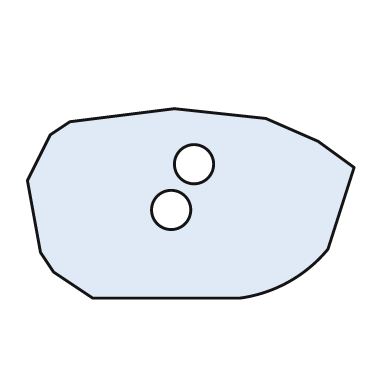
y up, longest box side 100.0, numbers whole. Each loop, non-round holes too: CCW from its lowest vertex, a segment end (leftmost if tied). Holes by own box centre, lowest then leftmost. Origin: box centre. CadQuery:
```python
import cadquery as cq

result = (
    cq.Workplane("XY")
    .moveTo(-30.0, -29.0)
    .lineTo(15.0, -29.0)
    .threePointArc((30.0, -24.0), (42.0, -14.0))
    .lineTo(50.0, 11.0)
    .lineTo(39.0, 19.0)
    .lineTo(23.0, 26.0)
    .lineTo(-5.0, 29.0)
    .lineTo(-37.0, 25.0)
    .lineTo(-43.0, 21.0)
    .lineTo(-50.0, 7.0)
    .lineTo(-46.0, -15.0)
    .lineTo(-42.0, -21.0)
    .close()
    .moveTo(-6.0, -2.0)
    .circle(6.0)
    .moveTo(1.0, 12.0)
    .circle(6.0)
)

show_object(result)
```